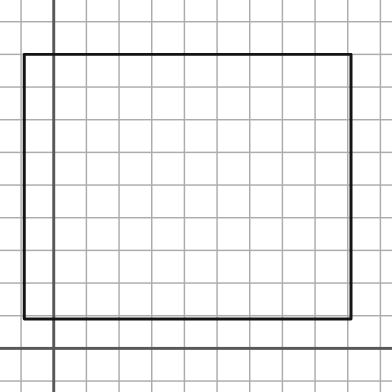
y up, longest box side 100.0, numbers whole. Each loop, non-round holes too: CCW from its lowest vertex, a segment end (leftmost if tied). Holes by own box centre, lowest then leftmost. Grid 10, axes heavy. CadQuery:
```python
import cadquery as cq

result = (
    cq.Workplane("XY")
    .moveTo(-9.0, 9.0)
    .lineTo(91.0, 9.0)
    .lineTo(91.0, 90.0)
    .lineTo(-9.0, 90.0)
    .close()
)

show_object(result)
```